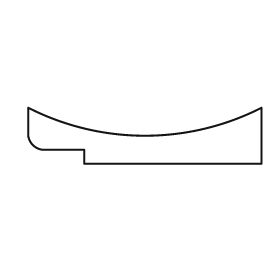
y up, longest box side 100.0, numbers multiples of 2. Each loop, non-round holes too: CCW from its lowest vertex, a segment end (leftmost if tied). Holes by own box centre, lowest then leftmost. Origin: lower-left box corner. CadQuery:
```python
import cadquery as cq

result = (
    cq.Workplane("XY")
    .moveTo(24.0, 0.0)
    .lineTo(100.0, 0.0)
    .lineTo(100.0, 24.0)
    .threePointArc((50.0, 12.0), (0.0, 24.0))
    .lineTo(0.0, 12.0)
    .threePointArc((2.0, 8.0), (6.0, 6.0))
    .lineTo(24.0, 6.0)
    .close()
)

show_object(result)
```